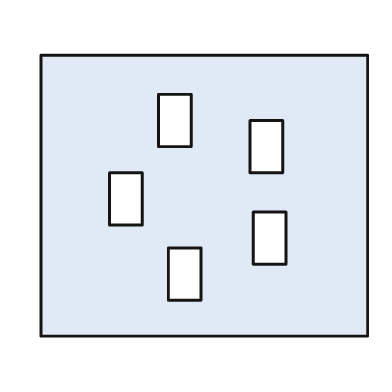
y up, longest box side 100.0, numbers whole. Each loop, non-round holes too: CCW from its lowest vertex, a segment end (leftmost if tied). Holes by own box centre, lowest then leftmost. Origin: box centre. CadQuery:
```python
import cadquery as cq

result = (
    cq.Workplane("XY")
    .moveTo(-50.0, -43.0)
    .lineTo(50.0, -43.0)
    .lineTo(50.0, 43.0)
    .lineTo(-50.0, 43.0)
    .close()
    .moveTo(-11.0, -32.0)
    .lineTo(-1.0, -32.0)
    .lineTo(-1.0, -16.0)
    .lineTo(-11.0, -16.0)
    .close()
    .moveTo(15.0, -21.0)
    .lineTo(25.0, -21.0)
    .lineTo(25.0, -5.0)
    .lineTo(15.0, -5.0)
    .close()
    .moveTo(-29.0, -9.0)
    .lineTo(-19.0, -9.0)
    .lineTo(-19.0, 7.0)
    .lineTo(-29.0, 7.0)
    .close()
    .moveTo(14.0, 7.0)
    .lineTo(24.0, 7.0)
    .lineTo(24.0, 23.0)
    .lineTo(14.0, 23.0)
    .close()
    .moveTo(-14.0, 15.0)
    .lineTo(-4.0, 15.0)
    .lineTo(-4.0, 31.0)
    .lineTo(-14.0, 31.0)
    .close()
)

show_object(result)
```